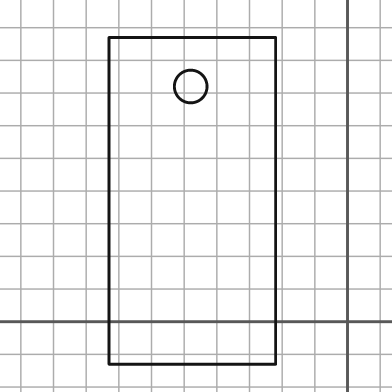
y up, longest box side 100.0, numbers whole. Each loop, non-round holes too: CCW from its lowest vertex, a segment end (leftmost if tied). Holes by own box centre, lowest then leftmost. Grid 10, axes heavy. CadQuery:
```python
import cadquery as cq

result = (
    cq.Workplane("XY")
    .moveTo(-73.0, -13.0)
    .lineTo(-22.0, -13.0)
    .lineTo(-22.0, 87.0)
    .lineTo(-73.0, 87.0)
    .close()
    .moveTo(-48.0, 72.0)
    .circle(5.0)
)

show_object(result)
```